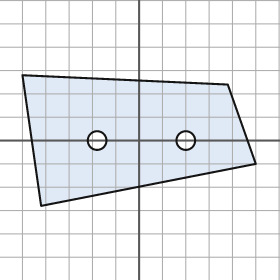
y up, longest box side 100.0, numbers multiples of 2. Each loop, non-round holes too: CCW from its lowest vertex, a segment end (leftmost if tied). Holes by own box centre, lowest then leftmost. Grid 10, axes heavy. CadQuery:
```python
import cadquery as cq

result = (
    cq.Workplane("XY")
    .moveTo(-42.0, -28.0)
    .lineTo(50.0, -10.0)
    .lineTo(38.0, 24.0)
    .lineTo(-50.0, 28.0)
    .close()
    .moveTo(-18.0, 0.0)
    .circle(4.0)
    .moveTo(20.0, 0.0)
    .circle(4.0)
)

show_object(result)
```